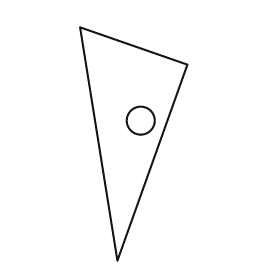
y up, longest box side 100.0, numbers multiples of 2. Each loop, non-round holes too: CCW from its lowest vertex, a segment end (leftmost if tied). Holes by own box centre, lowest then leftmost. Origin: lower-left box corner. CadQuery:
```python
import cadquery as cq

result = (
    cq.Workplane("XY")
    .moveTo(16.0, 0.0)
    .lineTo(46.0, 84.0)
    .lineTo(0.0, 100.0)
    .close()
    .moveTo(26.0, 60.0)
    .circle(6.0)
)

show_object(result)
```